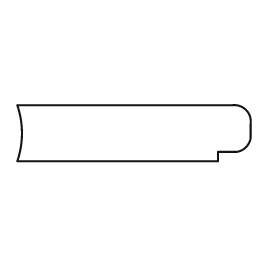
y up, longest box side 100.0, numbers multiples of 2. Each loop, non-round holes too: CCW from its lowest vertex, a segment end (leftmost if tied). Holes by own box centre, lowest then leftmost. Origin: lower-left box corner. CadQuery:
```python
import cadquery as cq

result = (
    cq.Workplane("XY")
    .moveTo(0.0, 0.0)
    .lineTo(86.0, 0.0)
    .lineTo(86.0, 4.0)
    .lineTo(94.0, 4.0)
    .threePointArc((98.0, 6.0), (100.0, 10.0))
    .lineTo(100.0, 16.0)
    .threePointArc((98.0, 22.0), (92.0, 24.0))
    .lineTo(0.0, 24.0)
    .threePointArc((2.0, 12.0), (0.0, 0.0))
    .close()
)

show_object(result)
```